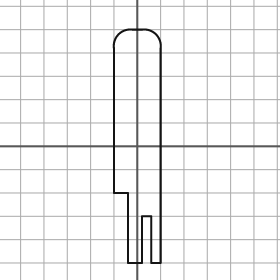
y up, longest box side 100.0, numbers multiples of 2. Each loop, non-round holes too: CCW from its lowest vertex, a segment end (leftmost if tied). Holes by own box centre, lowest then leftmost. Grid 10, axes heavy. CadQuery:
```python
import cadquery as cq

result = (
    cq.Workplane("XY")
    .moveTo(-4.0, -50.0)
    .lineTo(2.0, -50.0)
    .lineTo(2.0, -30.0)
    .lineTo(6.0, -30.0)
    .lineTo(6.0, -50.0)
    .lineTo(10.0, -50.0)
    .lineTo(10.0, 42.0)
    .threePointArc((8.0, 48.0), (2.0, 50.0))
    .lineTo(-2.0, 50.0)
    .threePointArc((-8.0, 48.0), (-10.0, 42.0))
    .lineTo(-10.0, -20.0)
    .lineTo(-4.0, -20.0)
    .close()
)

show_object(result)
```